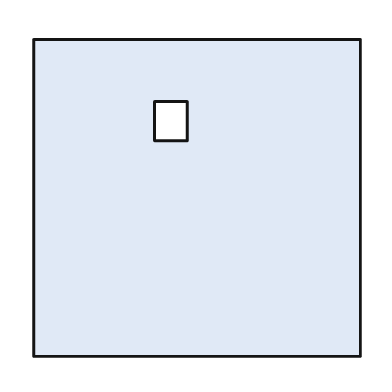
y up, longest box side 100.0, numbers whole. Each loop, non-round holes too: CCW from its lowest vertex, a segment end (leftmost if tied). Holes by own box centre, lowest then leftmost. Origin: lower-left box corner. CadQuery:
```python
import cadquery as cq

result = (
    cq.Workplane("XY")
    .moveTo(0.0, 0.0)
    .lineTo(100.0, 0.0)
    .lineTo(100.0, 97.0)
    .lineTo(0.0, 97.0)
    .close()
    .moveTo(37.0, 66.0)
    .lineTo(47.0, 66.0)
    .lineTo(47.0, 78.0)
    .lineTo(37.0, 78.0)
    .close()
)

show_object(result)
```